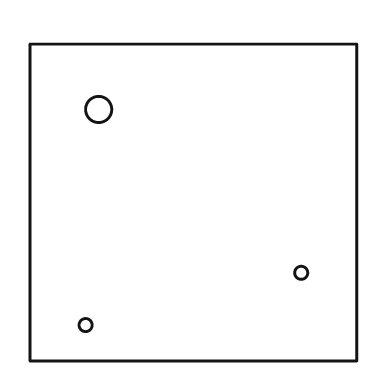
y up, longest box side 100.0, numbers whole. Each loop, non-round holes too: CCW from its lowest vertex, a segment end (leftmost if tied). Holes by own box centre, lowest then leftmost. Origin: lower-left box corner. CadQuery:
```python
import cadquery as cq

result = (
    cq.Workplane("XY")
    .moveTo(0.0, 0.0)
    .lineTo(100.0, 0.0)
    .lineTo(100.0, 97.0)
    .lineTo(0.0, 97.0)
    .close()
    .moveTo(17.0, 11.0)
    .circle(2.0)
    .moveTo(83.0, 27.0)
    .circle(2.0)
    .moveTo(21.0, 77.0)
    .circle(4.0)
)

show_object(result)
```